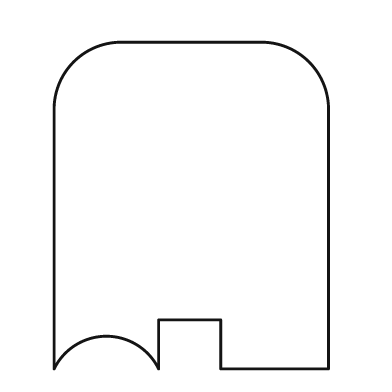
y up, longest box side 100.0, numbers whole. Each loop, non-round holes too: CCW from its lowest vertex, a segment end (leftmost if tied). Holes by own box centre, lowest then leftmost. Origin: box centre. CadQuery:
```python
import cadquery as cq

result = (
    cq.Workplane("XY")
    .moveTo(-42.0, -50.0)
    .threePointArc((-26.0, -40.0), (-10.0, -50.0))
    .lineTo(-10.0, -35.0)
    .lineTo(9.0, -35.0)
    .lineTo(9.0, -50.0)
    .lineTo(42.0, -50.0)
    .lineTo(42.0, 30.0)
    .threePointArc((36.0, 44.0), (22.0, 50.0))
    .lineTo(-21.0, 50.0)
    .threePointArc((-36.0, 44.0), (-42.0, 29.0))
    .close()
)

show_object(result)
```